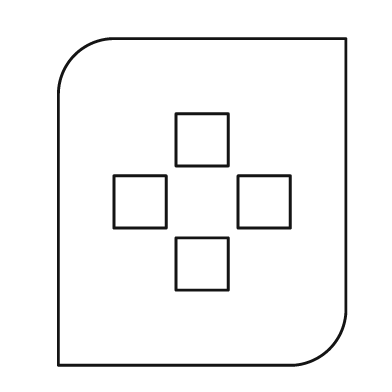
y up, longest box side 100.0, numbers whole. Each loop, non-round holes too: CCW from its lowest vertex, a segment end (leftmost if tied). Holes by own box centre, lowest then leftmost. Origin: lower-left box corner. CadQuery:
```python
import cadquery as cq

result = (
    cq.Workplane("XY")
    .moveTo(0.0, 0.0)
    .lineTo(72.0, 0.0)
    .threePointArc((83.0, 5.0), (88.0, 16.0))
    .lineTo(88.0, 100.0)
    .lineTo(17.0, 100.0)
    .threePointArc((5.0, 95.0), (0.0, 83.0))
    .close()
    .moveTo(36.0, 23.0)
    .lineTo(52.0, 23.0)
    .lineTo(52.0, 39.0)
    .lineTo(36.0, 39.0)
    .close()
    .moveTo(17.0, 42.0)
    .lineTo(33.0, 42.0)
    .lineTo(33.0, 58.0)
    .lineTo(17.0, 58.0)
    .close()
    .moveTo(55.0, 42.0)
    .lineTo(71.0, 42.0)
    .lineTo(71.0, 58.0)
    .lineTo(55.0, 58.0)
    .close()
    .moveTo(36.0, 61.0)
    .lineTo(52.0, 61.0)
    .lineTo(52.0, 77.0)
    .lineTo(36.0, 77.0)
    .close()
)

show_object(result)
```